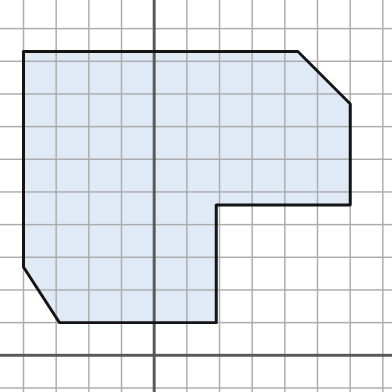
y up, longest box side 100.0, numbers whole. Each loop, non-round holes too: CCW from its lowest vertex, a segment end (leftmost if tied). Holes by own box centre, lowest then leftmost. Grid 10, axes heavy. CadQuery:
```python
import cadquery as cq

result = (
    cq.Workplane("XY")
    .moveTo(-29.0, 10.0)
    .lineTo(19.0, 10.0)
    .lineTo(19.0, 46.0)
    .lineTo(60.0, 46.0)
    .lineTo(60.0, 77.0)
    .lineTo(44.0, 93.0)
    .lineTo(-40.0, 93.0)
    .lineTo(-40.0, 27.0)
    .close()
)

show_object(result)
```